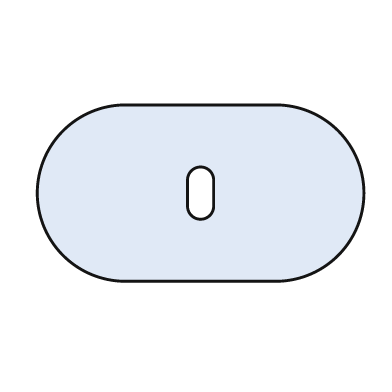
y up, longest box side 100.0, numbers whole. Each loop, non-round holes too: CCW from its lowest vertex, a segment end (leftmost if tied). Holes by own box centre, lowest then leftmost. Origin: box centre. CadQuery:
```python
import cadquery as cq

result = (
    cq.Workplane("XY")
    .moveTo(-23.0, -27.0)
    .lineTo(23.0, -27.0)
    .threePointArc((50.0, 0.0), (23.0, 27.0))
    .lineTo(-23.0, 27.0)
    .threePointArc((-50.0, 0.0), (-23.0, -27.0))
    .close()
    .moveTo(-4.0, -4.0)
    .threePointArc((0.0, -8.0), (4.0, -4.0))
    .lineTo(4.0, 4.0)
    .threePointArc((0.0, 8.0), (-4.0, 4.0))
    .close()
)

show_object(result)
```